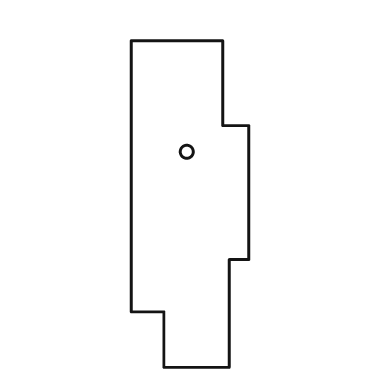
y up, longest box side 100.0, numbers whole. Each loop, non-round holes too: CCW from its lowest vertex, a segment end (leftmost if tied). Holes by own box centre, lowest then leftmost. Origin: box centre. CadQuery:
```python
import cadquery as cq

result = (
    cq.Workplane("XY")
    .moveTo(-8.0, -50.0)
    .lineTo(12.0, -50.0)
    .lineTo(12.0, -17.0)
    .lineTo(18.0, -17.0)
    .lineTo(18.0, 24.0)
    .lineTo(10.0, 24.0)
    .lineTo(10.0, 50.0)
    .lineTo(-18.0, 50.0)
    .lineTo(-18.0, -33.0)
    .lineTo(-8.0, -33.0)
    .close()
    .moveTo(-1.0, 16.0)
    .circle(2.0)
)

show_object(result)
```